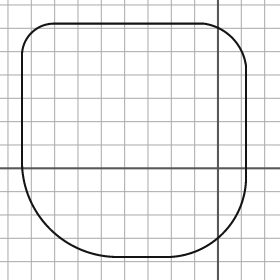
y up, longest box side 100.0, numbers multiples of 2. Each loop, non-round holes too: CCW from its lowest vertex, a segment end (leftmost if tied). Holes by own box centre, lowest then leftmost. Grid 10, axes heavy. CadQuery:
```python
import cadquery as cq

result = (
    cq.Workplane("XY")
    .moveTo(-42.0, -38.0)
    .lineTo(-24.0, -38.0)
    .threePointArc((2.0, -28.0), (12.0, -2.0))
    .lineTo(12.0, 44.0)
    .threePointArc((6.0, 56.0), (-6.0, 62.0))
    .lineTo(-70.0, 62.0)
    .threePointArc((-80.0, 58.0), (-84.0, 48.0))
    .lineTo(-84.0, 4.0)
    .threePointArc((-72.0, -26.0), (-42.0, -38.0))
    .close()
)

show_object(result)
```